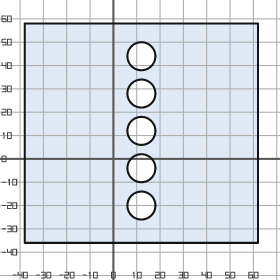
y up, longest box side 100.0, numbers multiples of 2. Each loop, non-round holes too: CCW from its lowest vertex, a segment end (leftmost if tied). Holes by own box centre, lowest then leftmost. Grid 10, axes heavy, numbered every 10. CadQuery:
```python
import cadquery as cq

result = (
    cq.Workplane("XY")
    .moveTo(-38.0, -36.0)
    .lineTo(62.0, -36.0)
    .lineTo(62.0, 58.0)
    .lineTo(-38.0, 58.0)
    .close()
    .moveTo(12.0, -20.0)
    .circle(6.0)
    .moveTo(12.0, -4.0)
    .circle(6.0)
    .moveTo(12.0, 12.0)
    .circle(6.0)
    .moveTo(12.0, 28.0)
    .circle(6.0)
    .moveTo(12.0, 44.0)
    .circle(6.0)
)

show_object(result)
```